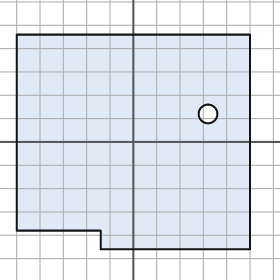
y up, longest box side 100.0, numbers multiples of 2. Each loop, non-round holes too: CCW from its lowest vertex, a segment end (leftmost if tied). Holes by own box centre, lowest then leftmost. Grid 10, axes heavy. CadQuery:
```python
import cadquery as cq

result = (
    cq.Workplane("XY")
    .moveTo(-14.0, -46.0)
    .lineTo(50.0, -46.0)
    .lineTo(50.0, 46.0)
    .lineTo(-50.0, 46.0)
    .lineTo(-50.0, -38.0)
    .lineTo(-14.0, -38.0)
    .close()
    .moveTo(32.0, 12.0)
    .circle(4.0)
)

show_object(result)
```